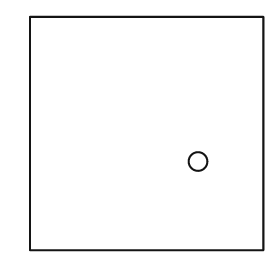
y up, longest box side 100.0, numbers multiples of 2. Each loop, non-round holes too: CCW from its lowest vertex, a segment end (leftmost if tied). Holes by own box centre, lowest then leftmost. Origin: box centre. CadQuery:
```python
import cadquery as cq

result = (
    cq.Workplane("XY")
    .moveTo(-50.0, -50.0)
    .lineTo(50.0, -50.0)
    .lineTo(50.0, 50.0)
    .lineTo(-50.0, 50.0)
    .close()
    .moveTo(22.0, -12.0)
    .circle(4.0)
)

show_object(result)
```